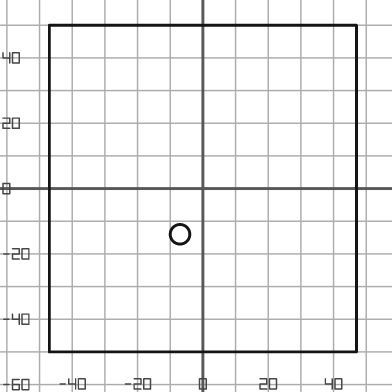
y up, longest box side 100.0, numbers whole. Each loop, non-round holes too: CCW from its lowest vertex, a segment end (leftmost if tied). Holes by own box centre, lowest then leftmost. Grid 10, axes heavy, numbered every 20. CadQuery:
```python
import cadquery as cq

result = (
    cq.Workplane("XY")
    .moveTo(-47.0, -50.0)
    .lineTo(47.0, -50.0)
    .lineTo(47.0, 50.0)
    .lineTo(-47.0, 50.0)
    .close()
    .moveTo(-7.0, -14.0)
    .circle(3.0)
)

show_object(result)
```